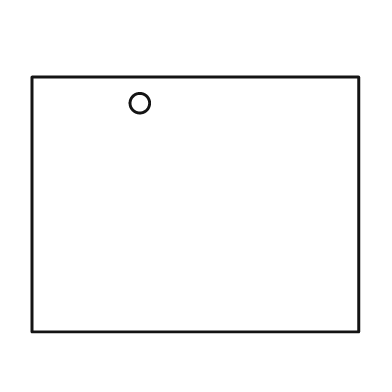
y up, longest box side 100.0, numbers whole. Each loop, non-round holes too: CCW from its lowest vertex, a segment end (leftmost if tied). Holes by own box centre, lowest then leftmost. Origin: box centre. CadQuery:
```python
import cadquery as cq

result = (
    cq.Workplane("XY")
    .moveTo(-50.0, -39.0)
    .lineTo(50.0, -39.0)
    .lineTo(50.0, 39.0)
    .lineTo(-50.0, 39.0)
    .close()
    .moveTo(-17.0, 31.0)
    .circle(3.0)
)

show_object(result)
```